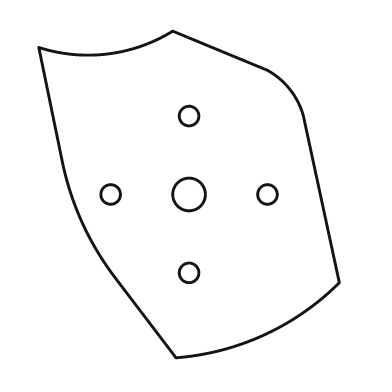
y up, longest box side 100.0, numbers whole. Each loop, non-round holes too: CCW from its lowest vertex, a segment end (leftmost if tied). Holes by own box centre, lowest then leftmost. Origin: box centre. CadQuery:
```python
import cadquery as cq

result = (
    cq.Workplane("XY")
    .moveTo(-4.0, -50.0)
    .threePointArc((23.0, -43.0), (46.0, -27.0))
    .lineTo(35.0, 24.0)
    .threePointArc((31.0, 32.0), (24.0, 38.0))
    .lineTo(-5.0, 50.0)
    .threePointArc((-25.0, 43.0), (-46.0, 45.0))
    .lineTo(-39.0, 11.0)
    .threePointArc((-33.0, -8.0), (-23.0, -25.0))
    .close()
    .moveTo(0.0, -24.0)
    .circle(3.0)
    .moveTo(-24.0, 0.0)
    .circle(3.0)
    .moveTo(0.0, 0.0)
    .circle(5.0)
    .moveTo(24.0, 0.0)
    .circle(3.0)
    .moveTo(0.0, 24.0)
    .circle(3.0)
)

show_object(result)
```